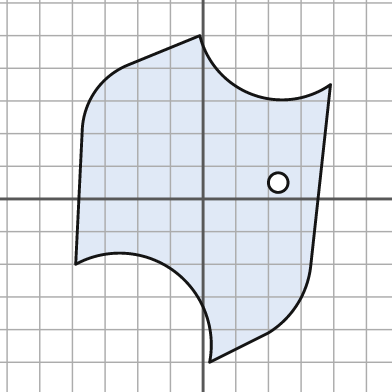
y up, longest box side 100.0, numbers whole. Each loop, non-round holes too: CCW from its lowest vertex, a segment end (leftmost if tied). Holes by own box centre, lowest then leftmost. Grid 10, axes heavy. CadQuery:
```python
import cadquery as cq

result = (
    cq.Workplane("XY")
    .moveTo(2.0, -50.0)
    .lineTo(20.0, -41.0)
    .threePointArc((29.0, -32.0), (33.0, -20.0))
    .lineTo(39.0, 35.0)
    .threePointArc((15.0, 32.0), (-1.0, 50.0))
    .lineTo(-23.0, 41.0)
    .threePointArc((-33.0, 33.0), (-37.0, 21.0))
    .lineTo(-39.0, -20.0)
    .threePointArc((-9.0, -22.0), (2.0, -50.0))
    .close()
    .moveTo(23.0, 5.0)
    .circle(3.0)
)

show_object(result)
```